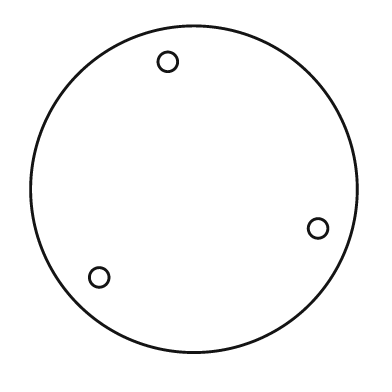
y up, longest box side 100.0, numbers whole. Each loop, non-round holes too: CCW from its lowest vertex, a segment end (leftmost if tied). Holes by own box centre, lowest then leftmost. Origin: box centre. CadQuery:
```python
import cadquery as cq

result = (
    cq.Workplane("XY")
    .moveTo(0.0, 0.0)
    .circle(50.0)
    .moveTo(-29.0, -27.0)
    .circle(3.0)
    .moveTo(38.0, -12.0)
    .circle(3.0)
    .moveTo(-8.0, 39.0)
    .circle(3.0)
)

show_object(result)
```